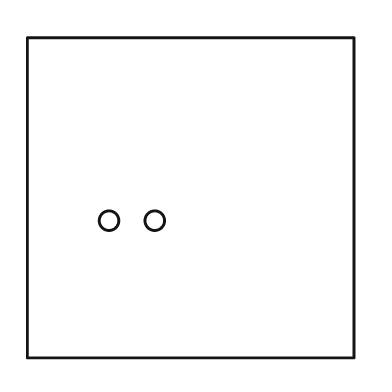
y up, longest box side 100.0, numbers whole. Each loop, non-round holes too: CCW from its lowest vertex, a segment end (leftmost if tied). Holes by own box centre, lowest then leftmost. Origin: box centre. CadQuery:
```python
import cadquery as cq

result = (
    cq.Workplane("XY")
    .moveTo(-50.0, -49.0)
    .lineTo(50.0, -49.0)
    .lineTo(50.0, 49.0)
    .lineTo(-50.0, 49.0)
    .close()
    .moveTo(-25.0, -7.0)
    .circle(3.0)
    .moveTo(-11.0, -7.0)
    .circle(3.0)
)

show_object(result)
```